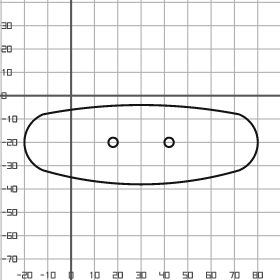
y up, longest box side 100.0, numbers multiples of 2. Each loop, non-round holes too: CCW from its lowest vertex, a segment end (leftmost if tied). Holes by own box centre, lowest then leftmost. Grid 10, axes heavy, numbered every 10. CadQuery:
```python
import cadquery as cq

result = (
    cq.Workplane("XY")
    .moveTo(-12.0, -32.0)
    .threePointArc((30.0, -38.0), (72.0, -32.0))
    .threePointArc((80.0, -20.0), (72.0, -8.0))
    .threePointArc((30.0, -4.0), (-12.0, -8.0))
    .threePointArc((-20.0, -20.0), (-12.0, -32.0))
    .close()
    .moveTo(18.0, -20.0)
    .circle(2.0)
    .moveTo(42.0, -20.0)
    .circle(2.0)
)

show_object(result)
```